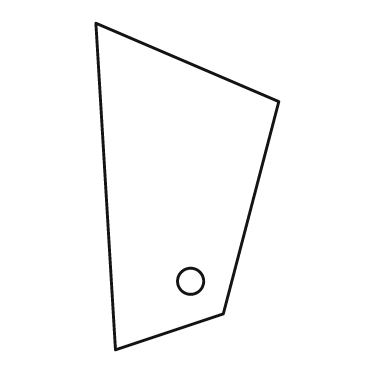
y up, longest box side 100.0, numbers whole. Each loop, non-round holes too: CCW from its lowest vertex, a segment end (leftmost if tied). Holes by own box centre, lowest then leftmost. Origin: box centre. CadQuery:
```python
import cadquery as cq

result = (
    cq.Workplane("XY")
    .moveTo(-22.0, -50.0)
    .lineTo(11.0, -39.0)
    .lineTo(28.0, 26.0)
    .lineTo(-28.0, 50.0)
    .close()
    .moveTo(1.0, -29.0)
    .circle(4.0)
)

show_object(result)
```